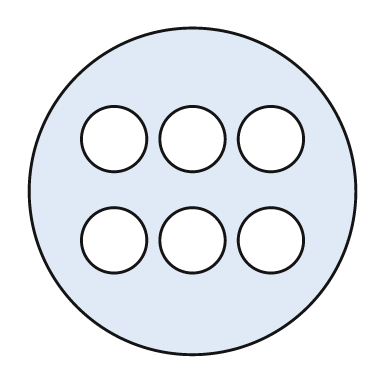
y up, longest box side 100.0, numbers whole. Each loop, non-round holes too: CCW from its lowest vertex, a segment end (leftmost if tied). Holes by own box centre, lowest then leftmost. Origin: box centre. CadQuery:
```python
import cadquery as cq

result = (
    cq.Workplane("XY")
    .moveTo(0.0, 0.0)
    .circle(50.0)
    .moveTo(-24.0, -15.0)
    .circle(10.0)
    .moveTo(0.0, -15.0)
    .circle(10.0)
    .moveTo(24.0, -15.0)
    .circle(10.0)
    .moveTo(-24.0, 16.0)
    .circle(10.0)
    .moveTo(0.0, 16.0)
    .circle(10.0)
    .moveTo(24.0, 16.0)
    .circle(10.0)
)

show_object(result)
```